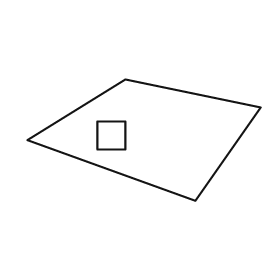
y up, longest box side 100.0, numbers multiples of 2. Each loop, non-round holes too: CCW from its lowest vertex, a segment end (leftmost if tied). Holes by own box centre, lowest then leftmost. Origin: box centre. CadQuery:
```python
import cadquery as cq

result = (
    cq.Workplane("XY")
    .moveTo(22.0, -26.0)
    .lineTo(50.0, 14.0)
    .lineTo(-8.0, 26.0)
    .lineTo(-50.0, 0.0)
    .close()
    .moveTo(-20.0, -4.0)
    .lineTo(-8.0, -4.0)
    .lineTo(-8.0, 8.0)
    .lineTo(-20.0, 8.0)
    .close()
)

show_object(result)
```